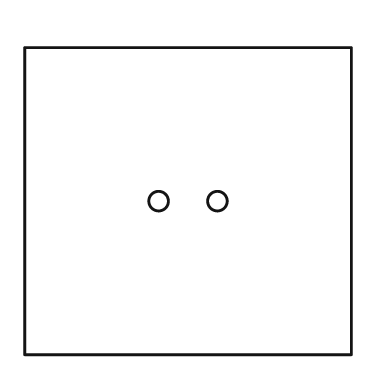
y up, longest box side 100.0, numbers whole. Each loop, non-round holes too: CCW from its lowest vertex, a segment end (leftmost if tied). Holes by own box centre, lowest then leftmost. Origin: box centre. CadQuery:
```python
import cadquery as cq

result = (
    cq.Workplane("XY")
    .moveTo(-50.0, -47.0)
    .lineTo(50.0, -47.0)
    .lineTo(50.0, 47.0)
    .lineTo(-50.0, 47.0)
    .close()
    .moveTo(-9.0, 0.0)
    .circle(3.0)
    .moveTo(9.0, 0.0)
    .circle(3.0)
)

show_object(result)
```